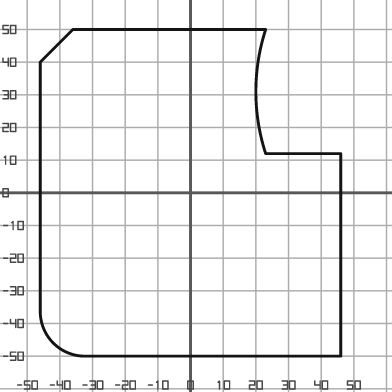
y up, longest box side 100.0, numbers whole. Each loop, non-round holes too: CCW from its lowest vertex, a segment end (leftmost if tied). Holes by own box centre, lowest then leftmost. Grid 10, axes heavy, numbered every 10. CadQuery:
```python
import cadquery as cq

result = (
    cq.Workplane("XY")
    .moveTo(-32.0, -50.0)
    .lineTo(46.0, -50.0)
    .lineTo(46.0, 12.0)
    .lineTo(23.0, 12.0)
    .threePointArc((20.0, 31.0), (23.0, 50.0))
    .lineTo(-36.0, 50.0)
    .lineTo(-46.0, 40.0)
    .lineTo(-46.0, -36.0)
    .threePointArc((-42.0, -46.0), (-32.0, -50.0))
    .close()
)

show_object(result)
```